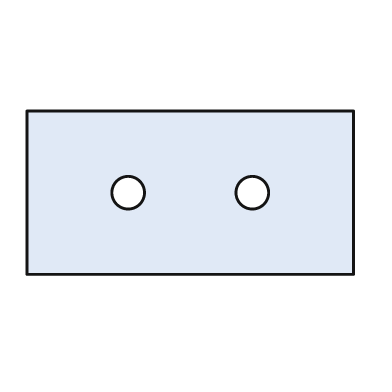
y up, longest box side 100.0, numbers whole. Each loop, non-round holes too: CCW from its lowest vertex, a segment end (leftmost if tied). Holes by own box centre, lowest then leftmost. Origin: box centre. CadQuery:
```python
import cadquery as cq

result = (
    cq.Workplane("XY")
    .moveTo(-50.0, -25.0)
    .lineTo(50.0, -25.0)
    .lineTo(50.0, 25.0)
    .lineTo(-50.0, 25.0)
    .close()
    .moveTo(-19.0, 0.0)
    .circle(5.0)
    .moveTo(19.0, 0.0)
    .circle(5.0)
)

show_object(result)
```